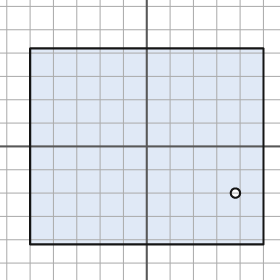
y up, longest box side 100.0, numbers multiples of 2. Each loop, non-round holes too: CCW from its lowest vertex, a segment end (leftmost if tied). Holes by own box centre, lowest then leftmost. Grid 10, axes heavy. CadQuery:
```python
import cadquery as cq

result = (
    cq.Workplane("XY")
    .moveTo(-50.0, -42.0)
    .lineTo(50.0, -42.0)
    .lineTo(50.0, 42.0)
    .lineTo(-50.0, 42.0)
    .close()
    .moveTo(38.0, -20.0)
    .circle(2.0)
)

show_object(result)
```